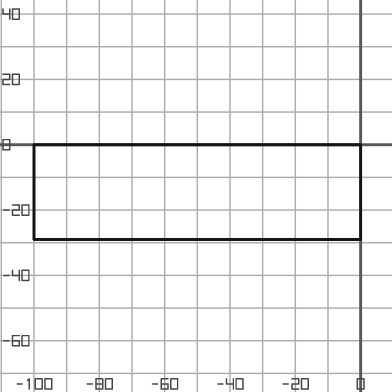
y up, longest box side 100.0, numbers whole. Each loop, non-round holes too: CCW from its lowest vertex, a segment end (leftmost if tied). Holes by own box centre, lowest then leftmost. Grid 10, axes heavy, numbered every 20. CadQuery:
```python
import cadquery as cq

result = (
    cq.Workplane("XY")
    .moveTo(-100.0, -29.0)
    .lineTo(0.0, -29.0)
    .lineTo(0.0, 0.0)
    .lineTo(-100.0, 0.0)
    .close()
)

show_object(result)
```